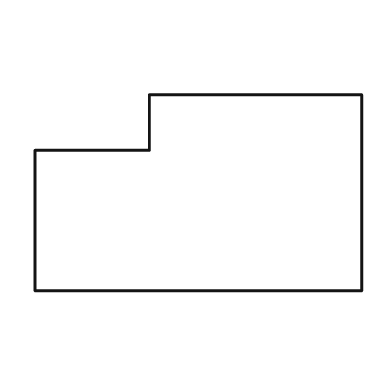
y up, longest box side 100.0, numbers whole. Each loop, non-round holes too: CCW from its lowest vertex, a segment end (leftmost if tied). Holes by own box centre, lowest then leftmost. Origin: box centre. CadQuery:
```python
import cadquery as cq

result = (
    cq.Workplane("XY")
    .moveTo(-50.0, -30.0)
    .lineTo(50.0, -30.0)
    .lineTo(50.0, 30.0)
    .lineTo(-15.0, 30.0)
    .lineTo(-15.0, 13.0)
    .lineTo(-50.0, 13.0)
    .close()
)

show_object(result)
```